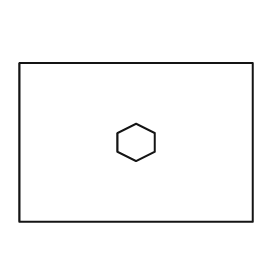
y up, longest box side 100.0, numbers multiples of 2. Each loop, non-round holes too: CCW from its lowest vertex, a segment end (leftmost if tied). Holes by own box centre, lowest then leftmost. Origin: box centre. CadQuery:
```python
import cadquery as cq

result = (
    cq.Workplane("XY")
    .moveTo(-50.0, -34.0)
    .lineTo(50.0, -34.0)
    .lineTo(50.0, 34.0)
    .lineTo(-50.0, 34.0)
    .close()
    .moveTo(0.0, -8.0)
    .lineTo(8.0, -4.0)
    .lineTo(8.0, 4.0)
    .lineTo(0.0, 8.0)
    .lineTo(-8.0, 4.0)
    .lineTo(-8.0, -4.0)
    .close()
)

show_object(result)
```